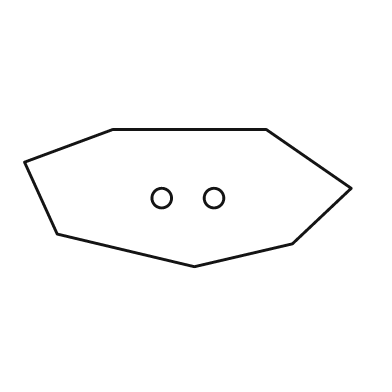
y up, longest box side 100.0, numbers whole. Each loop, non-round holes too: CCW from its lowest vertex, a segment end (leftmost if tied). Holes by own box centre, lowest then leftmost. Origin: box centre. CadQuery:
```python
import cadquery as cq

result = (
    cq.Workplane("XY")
    .moveTo(2.0, -21.0)
    .lineTo(32.0, -14.0)
    .lineTo(50.0, 3.0)
    .lineTo(24.0, 21.0)
    .lineTo(-23.0, 21.0)
    .lineTo(-50.0, 11.0)
    .lineTo(-40.0, -11.0)
    .close()
    .moveTo(-8.0, 0.0)
    .circle(3.0)
    .moveTo(8.0, 0.0)
    .circle(3.0)
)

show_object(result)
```